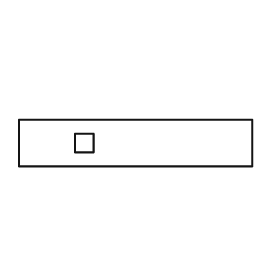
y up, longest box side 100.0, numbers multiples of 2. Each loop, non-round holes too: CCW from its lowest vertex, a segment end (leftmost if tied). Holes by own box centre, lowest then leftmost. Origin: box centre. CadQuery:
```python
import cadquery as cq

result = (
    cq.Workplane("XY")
    .moveTo(-50.0, -10.0)
    .lineTo(50.0, -10.0)
    .lineTo(50.0, 10.0)
    .lineTo(-50.0, 10.0)
    .close()
    .moveTo(-26.0, -4.0)
    .lineTo(-18.0, -4.0)
    .lineTo(-18.0, 4.0)
    .lineTo(-26.0, 4.0)
    .close()
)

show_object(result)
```